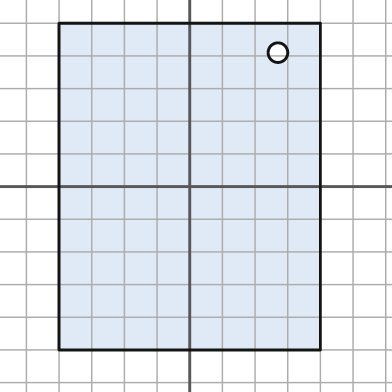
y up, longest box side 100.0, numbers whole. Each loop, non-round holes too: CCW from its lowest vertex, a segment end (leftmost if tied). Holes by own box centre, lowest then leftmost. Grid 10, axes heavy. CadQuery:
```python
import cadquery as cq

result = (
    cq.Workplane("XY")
    .moveTo(-40.0, -50.0)
    .lineTo(40.0, -50.0)
    .lineTo(40.0, 50.0)
    .lineTo(-40.0, 50.0)
    .close()
    .moveTo(27.0, 41.0)
    .circle(3.0)
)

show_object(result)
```